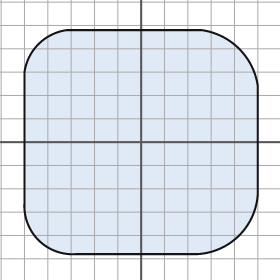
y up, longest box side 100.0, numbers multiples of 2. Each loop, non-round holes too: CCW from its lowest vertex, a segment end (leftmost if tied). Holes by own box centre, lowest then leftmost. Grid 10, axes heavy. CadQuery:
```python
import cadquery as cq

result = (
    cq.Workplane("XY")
    .moveTo(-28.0, -48.0)
    .lineTo(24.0, -48.0)
    .threePointArc((42.0, -40.0), (50.0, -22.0))
    .lineTo(50.0, 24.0)
    .threePointArc((42.0, 40.0), (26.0, 48.0))
    .lineTo(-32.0, 48.0)
    .threePointArc((-44.0, 42.0), (-50.0, 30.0))
    .lineTo(-50.0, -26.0)
    .threePointArc((-44.0, -42.0), (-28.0, -48.0))
    .close()
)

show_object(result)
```